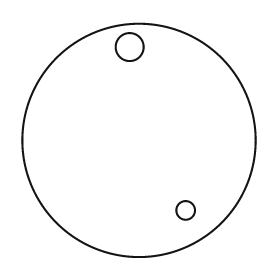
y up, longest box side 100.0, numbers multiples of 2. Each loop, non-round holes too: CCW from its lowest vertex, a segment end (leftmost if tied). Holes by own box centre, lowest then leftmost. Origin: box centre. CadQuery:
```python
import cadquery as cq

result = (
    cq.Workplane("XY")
    .moveTo(0.0, 0.0)
    .circle(50.0)
    .moveTo(20.0, -30.0)
    .circle(4.0)
    .moveTo(-4.0, 40.0)
    .circle(6.0)
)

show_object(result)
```